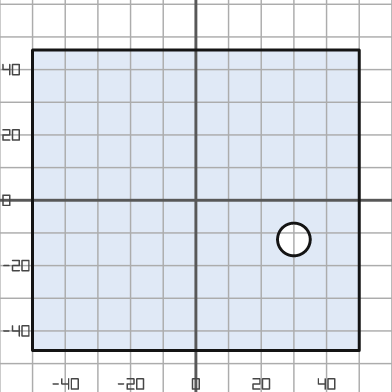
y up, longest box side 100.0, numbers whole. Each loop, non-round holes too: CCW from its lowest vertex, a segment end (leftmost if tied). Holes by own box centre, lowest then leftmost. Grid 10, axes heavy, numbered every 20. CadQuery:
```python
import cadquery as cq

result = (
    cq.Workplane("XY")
    .moveTo(-50.0, -46.0)
    .lineTo(50.0, -46.0)
    .lineTo(50.0, 46.0)
    .lineTo(-50.0, 46.0)
    .close()
    .moveTo(30.0, -12.0)
    .circle(5.0)
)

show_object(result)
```